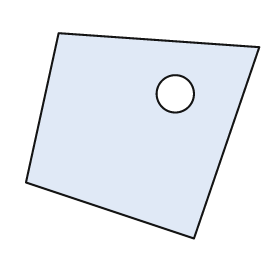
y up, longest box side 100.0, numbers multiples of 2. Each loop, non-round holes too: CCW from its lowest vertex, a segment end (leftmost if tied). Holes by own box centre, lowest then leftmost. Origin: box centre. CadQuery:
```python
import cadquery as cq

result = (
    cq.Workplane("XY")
    .moveTo(22.0, -44.0)
    .lineTo(50.0, 38.0)
    .lineTo(-36.0, 44.0)
    .lineTo(-50.0, -20.0)
    .close()
    .moveTo(14.0, 18.0)
    .circle(8.0)
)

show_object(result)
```